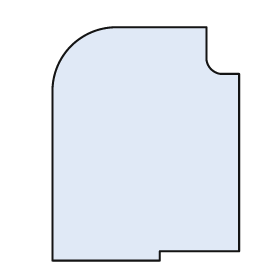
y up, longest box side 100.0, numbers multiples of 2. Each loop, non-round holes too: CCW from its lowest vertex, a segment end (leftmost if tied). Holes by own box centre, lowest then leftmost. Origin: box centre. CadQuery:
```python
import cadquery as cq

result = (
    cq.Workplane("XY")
    .moveTo(-40.0, -50.0)
    .lineTo(6.0, -50.0)
    .lineTo(6.0, -46.0)
    .lineTo(40.0, -46.0)
    .lineTo(40.0, 30.0)
    .lineTo(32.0, 30.0)
    .threePointArc((28.0, 32.0), (26.0, 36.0))
    .lineTo(26.0, 50.0)
    .lineTo(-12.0, 50.0)
    .threePointArc((-32.0, 42.0), (-40.0, 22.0))
    .close()
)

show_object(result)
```